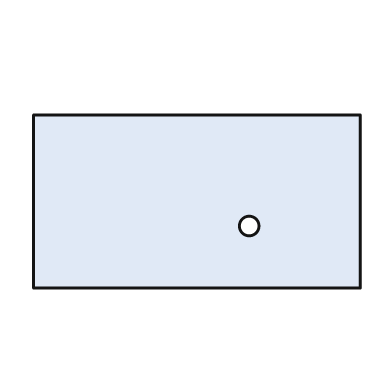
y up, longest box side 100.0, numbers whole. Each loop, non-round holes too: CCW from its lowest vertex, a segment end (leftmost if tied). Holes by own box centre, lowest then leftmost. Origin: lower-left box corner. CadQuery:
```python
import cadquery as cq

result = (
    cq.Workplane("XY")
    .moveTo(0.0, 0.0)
    .lineTo(100.0, 0.0)
    .lineTo(100.0, 53.0)
    .lineTo(0.0, 53.0)
    .close()
    .moveTo(66.0, 19.0)
    .circle(3.0)
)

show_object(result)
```